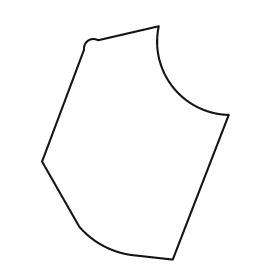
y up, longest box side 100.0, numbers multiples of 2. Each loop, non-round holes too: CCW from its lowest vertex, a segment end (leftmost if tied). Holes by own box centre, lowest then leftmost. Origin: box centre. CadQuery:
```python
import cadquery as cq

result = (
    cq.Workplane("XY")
    .moveTo(16.0, -50.0)
    .lineTo(40.0, 12.0)
    .threePointArc((16.0, 24.0), (10.0, 50.0))
    .lineTo(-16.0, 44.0)
    .threePointArc((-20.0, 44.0), (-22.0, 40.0))
    .lineTo(-40.0, -8.0)
    .lineTo(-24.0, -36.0)
    .threePointArc((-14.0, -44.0), (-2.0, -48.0))
    .close()
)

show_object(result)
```